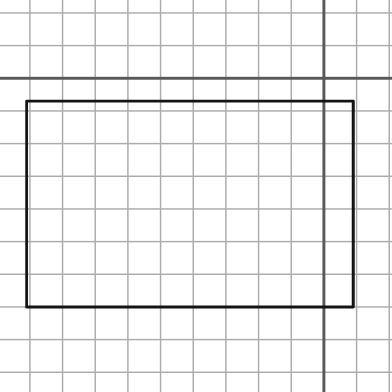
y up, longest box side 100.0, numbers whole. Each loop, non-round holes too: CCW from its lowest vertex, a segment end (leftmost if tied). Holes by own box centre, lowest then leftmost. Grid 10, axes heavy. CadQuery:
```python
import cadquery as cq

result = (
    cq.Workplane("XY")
    .moveTo(-91.0, -70.0)
    .lineTo(9.0, -70.0)
    .lineTo(9.0, -7.0)
    .lineTo(-91.0, -7.0)
    .close()
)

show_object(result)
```